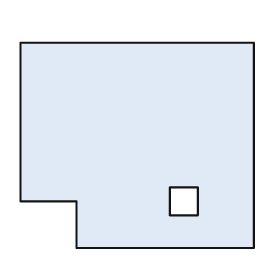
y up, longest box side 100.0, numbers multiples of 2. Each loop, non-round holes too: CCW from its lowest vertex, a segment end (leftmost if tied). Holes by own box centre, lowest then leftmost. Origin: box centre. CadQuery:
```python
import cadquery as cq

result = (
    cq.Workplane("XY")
    .moveTo(-26.0, -44.0)
    .lineTo(50.0, -44.0)
    .lineTo(50.0, 44.0)
    .lineTo(-50.0, 44.0)
    .lineTo(-50.0, -24.0)
    .lineTo(-26.0, -24.0)
    .close()
    .moveTo(14.0, -30.0)
    .lineTo(26.0, -30.0)
    .lineTo(26.0, -18.0)
    .lineTo(14.0, -18.0)
    .close()
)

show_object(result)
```